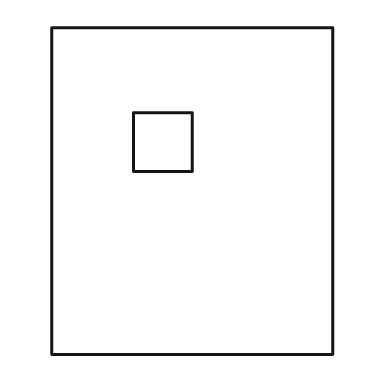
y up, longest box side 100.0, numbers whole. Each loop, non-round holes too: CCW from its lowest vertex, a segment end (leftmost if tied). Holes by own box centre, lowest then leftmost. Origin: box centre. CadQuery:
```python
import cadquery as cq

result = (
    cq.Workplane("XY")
    .moveTo(-43.0, -50.0)
    .lineTo(43.0, -50.0)
    .lineTo(43.0, 50.0)
    .lineTo(-43.0, 50.0)
    .close()
    .moveTo(-18.0, 6.0)
    .lineTo(0.0, 6.0)
    .lineTo(0.0, 24.0)
    .lineTo(-18.0, 24.0)
    .close()
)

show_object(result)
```